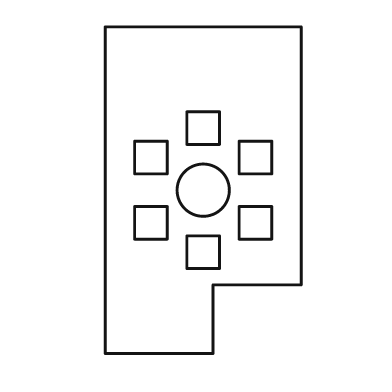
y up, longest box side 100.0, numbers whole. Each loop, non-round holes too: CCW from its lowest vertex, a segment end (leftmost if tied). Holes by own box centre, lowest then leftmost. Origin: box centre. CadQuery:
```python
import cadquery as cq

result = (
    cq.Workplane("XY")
    .moveTo(-30.0, -50.0)
    .lineTo(3.0, -50.0)
    .lineTo(3.0, -29.0)
    .lineTo(30.0, -29.0)
    .lineTo(30.0, 50.0)
    .lineTo(-30.0, 50.0)
    .close()
    .moveTo(-5.0, -24.0)
    .lineTo(5.0, -24.0)
    .lineTo(5.0, -14.0)
    .lineTo(-5.0, -14.0)
    .close()
    .moveTo(-21.0, -15.0)
    .lineTo(-11.0, -15.0)
    .lineTo(-11.0, -5.0)
    .lineTo(-21.0, -5.0)
    .close()
    .moveTo(11.0, -15.0)
    .lineTo(21.0, -15.0)
    .lineTo(21.0, -5.0)
    .lineTo(11.0, -5.0)
    .close()
    .moveTo(0.0, 0.0)
    .circle(8.0)
    .moveTo(-21.0, 5.0)
    .lineTo(-11.0, 5.0)
    .lineTo(-11.0, 15.0)
    .lineTo(-21.0, 15.0)
    .close()
    .moveTo(11.0, 5.0)
    .lineTo(21.0, 5.0)
    .lineTo(21.0, 15.0)
    .lineTo(11.0, 15.0)
    .close()
    .moveTo(-5.0, 14.0)
    .lineTo(5.0, 14.0)
    .lineTo(5.0, 24.0)
    .lineTo(-5.0, 24.0)
    .close()
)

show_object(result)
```